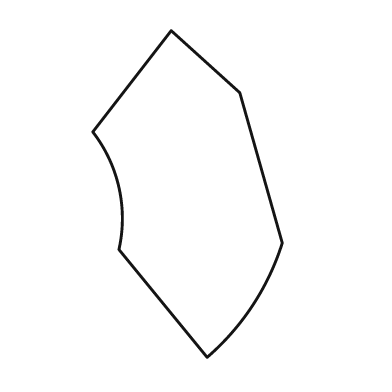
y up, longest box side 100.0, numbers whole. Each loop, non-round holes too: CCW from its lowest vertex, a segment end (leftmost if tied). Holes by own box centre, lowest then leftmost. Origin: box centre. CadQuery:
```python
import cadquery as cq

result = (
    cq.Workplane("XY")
    .moveTo(6.0, -50.0)
    .threePointArc((20.0, -34.0), (29.0, -15.0))
    .lineTo(16.0, 31.0)
    .lineTo(-5.0, 50.0)
    .lineTo(-29.0, 19.0)
    .threePointArc((-21.0, 2.0), (-21.0, -17.0))
    .close()
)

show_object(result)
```